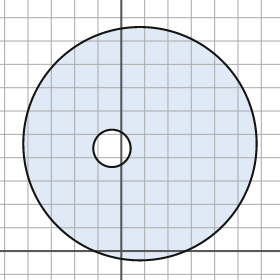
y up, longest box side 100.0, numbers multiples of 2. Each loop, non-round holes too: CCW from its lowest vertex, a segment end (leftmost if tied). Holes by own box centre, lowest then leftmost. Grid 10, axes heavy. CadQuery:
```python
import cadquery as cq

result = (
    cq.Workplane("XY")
    .moveTo(8.0, 46.0)
    .circle(50.0)
    .moveTo(-4.0, 44.0)
    .circle(8.0)
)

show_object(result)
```